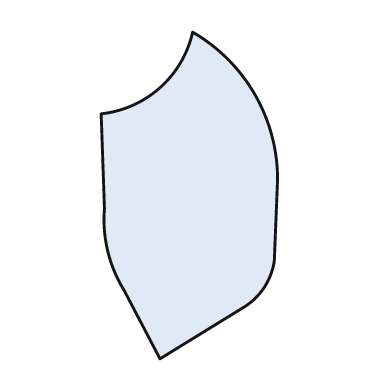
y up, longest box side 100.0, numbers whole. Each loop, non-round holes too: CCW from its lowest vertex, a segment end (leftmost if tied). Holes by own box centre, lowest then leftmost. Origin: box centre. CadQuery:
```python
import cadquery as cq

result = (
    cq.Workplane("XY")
    .moveTo(-9.0, -50.0)
    .lineTo(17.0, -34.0)
    .threePointArc((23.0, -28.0), (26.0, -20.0))
    .lineTo(27.0, 5.0)
    .threePointArc((20.0, 31.0), (1.0, 50.0))
    .threePointArc((-9.0, 33.0), (-27.0, 25.0))
    .lineTo(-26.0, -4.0)
    .threePointArc((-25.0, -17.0), (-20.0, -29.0))
    .close()
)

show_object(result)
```